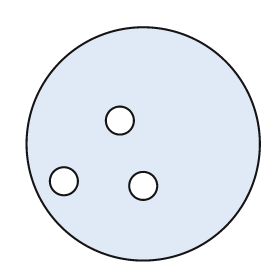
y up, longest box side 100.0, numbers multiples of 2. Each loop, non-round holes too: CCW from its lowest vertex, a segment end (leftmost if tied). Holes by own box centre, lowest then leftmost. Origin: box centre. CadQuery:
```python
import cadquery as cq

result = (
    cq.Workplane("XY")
    .moveTo(0.0, 0.0)
    .circle(50.0)
    .moveTo(0.0, -18.0)
    .circle(6.0)
    .moveTo(-34.0, -16.0)
    .circle(6.0)
    .moveTo(-10.0, 10.0)
    .circle(6.0)
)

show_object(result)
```